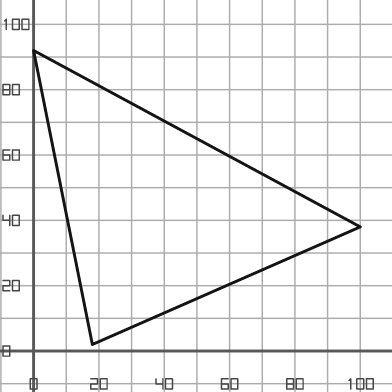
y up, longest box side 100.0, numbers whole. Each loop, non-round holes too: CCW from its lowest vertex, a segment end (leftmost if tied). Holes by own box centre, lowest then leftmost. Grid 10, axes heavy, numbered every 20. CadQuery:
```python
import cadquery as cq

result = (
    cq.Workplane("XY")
    .moveTo(18.0, 2.0)
    .lineTo(100.0, 38.0)
    .lineTo(0.0, 92.0)
    .close()
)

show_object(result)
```